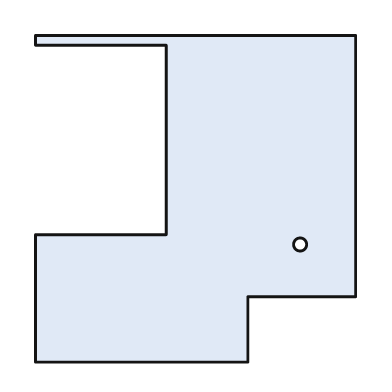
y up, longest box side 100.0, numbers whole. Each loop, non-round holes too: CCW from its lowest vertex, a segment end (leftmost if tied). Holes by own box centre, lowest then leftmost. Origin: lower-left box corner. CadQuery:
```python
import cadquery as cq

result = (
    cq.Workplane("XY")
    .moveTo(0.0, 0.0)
    .lineTo(65.0, 0.0)
    .lineTo(65.0, 20.0)
    .lineTo(98.0, 20.0)
    .lineTo(98.0, 100.0)
    .lineTo(0.0, 100.0)
    .lineTo(0.0, 97.0)
    .lineTo(40.0, 97.0)
    .lineTo(40.0, 39.0)
    .lineTo(0.0, 39.0)
    .close()
    .moveTo(81.0, 36.0)
    .circle(2.0)
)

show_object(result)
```